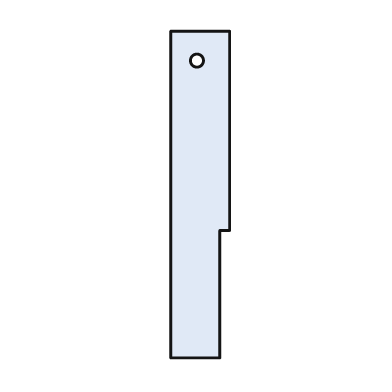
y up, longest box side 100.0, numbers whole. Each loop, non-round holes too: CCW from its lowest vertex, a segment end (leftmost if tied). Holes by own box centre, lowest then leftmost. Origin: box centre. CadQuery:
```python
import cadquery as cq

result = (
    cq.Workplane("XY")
    .moveTo(-9.0, -50.0)
    .lineTo(6.0, -50.0)
    .lineTo(6.0, -11.0)
    .lineTo(9.0, -11.0)
    .lineTo(9.0, 50.0)
    .lineTo(-9.0, 50.0)
    .close()
    .moveTo(-1.0, 41.0)
    .circle(2.0)
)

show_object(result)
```